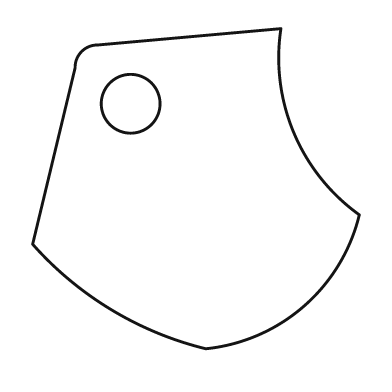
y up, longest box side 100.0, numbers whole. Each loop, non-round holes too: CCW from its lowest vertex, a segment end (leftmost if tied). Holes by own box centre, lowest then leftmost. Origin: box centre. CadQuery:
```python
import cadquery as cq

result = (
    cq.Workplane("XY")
    .moveTo(3.0, -49.0)
    .threePointArc((33.0, -36.0), (50.0, -8.0))
    .threePointArc((30.0, 17.0), (26.0, 49.0))
    .lineTo(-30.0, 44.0)
    .threePointArc((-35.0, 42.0), (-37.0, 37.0))
    .lineTo(-50.0, -17.0)
    .threePointArc((-26.0, -37.0), (3.0, -49.0))
    .close()
    .moveTo(-20.0, 26.0)
    .circle(9.0)
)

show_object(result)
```